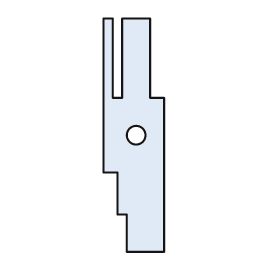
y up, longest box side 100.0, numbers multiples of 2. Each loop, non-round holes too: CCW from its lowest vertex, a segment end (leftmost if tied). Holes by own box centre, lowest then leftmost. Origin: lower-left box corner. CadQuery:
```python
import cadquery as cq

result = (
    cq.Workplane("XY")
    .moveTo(10.0, 0.0)
    .lineTo(26.0, 0.0)
    .lineTo(26.0, 66.0)
    .lineTo(20.0, 66.0)
    .lineTo(20.0, 100.0)
    .lineTo(8.0, 100.0)
    .lineTo(8.0, 66.0)
    .lineTo(4.0, 66.0)
    .lineTo(4.0, 100.0)
    .lineTo(0.0, 100.0)
    .lineTo(0.0, 34.0)
    .lineTo(6.0, 34.0)
    .lineTo(6.0, 16.0)
    .lineTo(10.0, 16.0)
    .close()
    .moveTo(14.0, 50.0)
    .circle(4.0)
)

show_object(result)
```